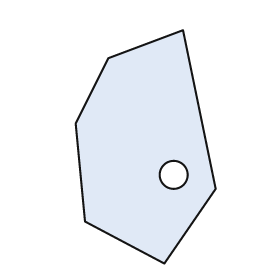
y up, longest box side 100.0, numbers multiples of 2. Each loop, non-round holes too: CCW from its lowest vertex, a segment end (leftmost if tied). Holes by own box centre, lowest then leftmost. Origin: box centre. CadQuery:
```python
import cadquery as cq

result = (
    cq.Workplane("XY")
    .moveTo(8.0, -50.0)
    .lineTo(30.0, -18.0)
    .lineTo(16.0, 50.0)
    .lineTo(-16.0, 38.0)
    .lineTo(-30.0, 10.0)
    .lineTo(-26.0, -32.0)
    .close()
    .moveTo(12.0, -12.0)
    .circle(6.0)
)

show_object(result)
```